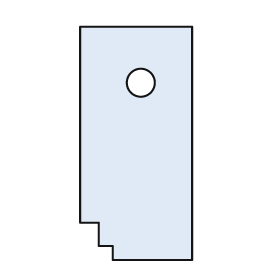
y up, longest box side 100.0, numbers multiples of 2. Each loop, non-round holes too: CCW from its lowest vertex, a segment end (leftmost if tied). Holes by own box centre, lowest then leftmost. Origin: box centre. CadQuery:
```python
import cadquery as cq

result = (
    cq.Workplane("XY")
    .moveTo(-10.0, -50.0)
    .lineTo(24.0, -50.0)
    .lineTo(24.0, 50.0)
    .lineTo(-24.0, 50.0)
    .lineTo(-24.0, -34.0)
    .lineTo(-16.0, -34.0)
    .lineTo(-16.0, -44.0)
    .lineTo(-10.0, -44.0)
    .close()
    .moveTo(2.0, 26.0)
    .circle(6.0)
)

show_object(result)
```